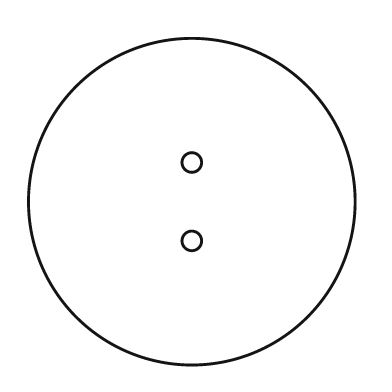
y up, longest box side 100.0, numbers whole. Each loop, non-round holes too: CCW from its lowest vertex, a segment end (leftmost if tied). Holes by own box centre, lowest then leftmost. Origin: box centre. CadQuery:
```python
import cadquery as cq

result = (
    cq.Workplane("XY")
    .moveTo(0.0, 0.0)
    .circle(50.0)
    .moveTo(0.0, -12.0)
    .circle(3.0)
    .moveTo(0.0, 12.0)
    .circle(3.0)
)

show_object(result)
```